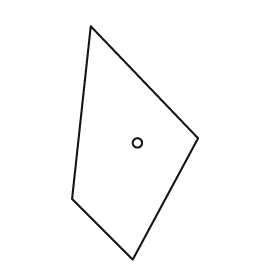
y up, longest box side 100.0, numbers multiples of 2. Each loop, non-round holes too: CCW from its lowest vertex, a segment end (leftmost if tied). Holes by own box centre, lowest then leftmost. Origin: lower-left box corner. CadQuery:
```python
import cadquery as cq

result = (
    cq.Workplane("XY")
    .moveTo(26.0, 0.0)
    .lineTo(54.0, 52.0)
    .lineTo(8.0, 100.0)
    .lineTo(0.0, 26.0)
    .close()
    .moveTo(28.0, 50.0)
    .circle(2.0)
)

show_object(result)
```